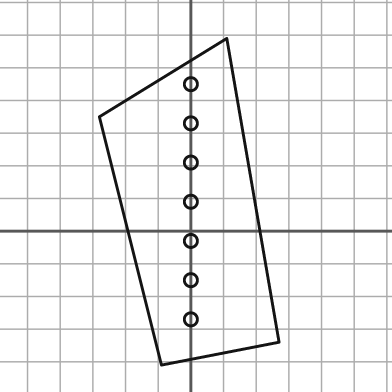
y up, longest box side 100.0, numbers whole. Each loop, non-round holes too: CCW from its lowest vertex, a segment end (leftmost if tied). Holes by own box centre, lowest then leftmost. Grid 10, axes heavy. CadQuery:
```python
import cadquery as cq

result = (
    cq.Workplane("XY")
    .moveTo(-9.0, -41.0)
    .lineTo(27.0, -34.0)
    .lineTo(11.0, 59.0)
    .lineTo(-28.0, 35.0)
    .close()
    .moveTo(0.0, -27.0)
    .circle(2.0)
    .moveTo(0.0, -15.0)
    .circle(2.0)
    .moveTo(0.0, -3.0)
    .circle(2.0)
    .moveTo(0.0, 9.0)
    .circle(2.0)
    .moveTo(0.0, 21.0)
    .circle(2.0)
    .moveTo(0.0, 33.0)
    .circle(2.0)
    .moveTo(0.0, 45.0)
    .circle(2.0)
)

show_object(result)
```